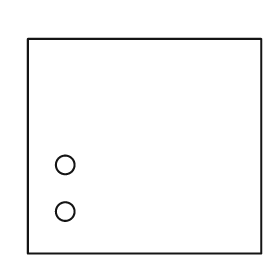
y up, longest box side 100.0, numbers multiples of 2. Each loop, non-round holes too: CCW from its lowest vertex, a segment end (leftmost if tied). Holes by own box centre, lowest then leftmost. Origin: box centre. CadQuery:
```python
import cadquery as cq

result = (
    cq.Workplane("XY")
    .moveTo(-50.0, -46.0)
    .lineTo(50.0, -46.0)
    .lineTo(50.0, 46.0)
    .lineTo(-50.0, 46.0)
    .close()
    .moveTo(-34.0, -28.0)
    .circle(4.0)
    .moveTo(-34.0, -8.0)
    .circle(4.0)
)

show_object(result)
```